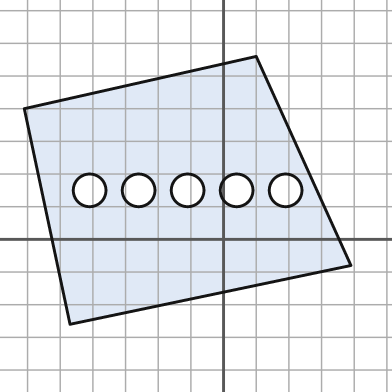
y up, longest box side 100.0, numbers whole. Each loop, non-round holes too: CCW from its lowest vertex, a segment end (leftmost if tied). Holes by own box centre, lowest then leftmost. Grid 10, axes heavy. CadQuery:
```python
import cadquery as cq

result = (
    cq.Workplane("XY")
    .moveTo(-47.0, -26.0)
    .lineTo(39.0, -8.0)
    .lineTo(10.0, 56.0)
    .lineTo(-61.0, 40.0)
    .close()
    .moveTo(-41.0, 15.0)
    .circle(5.0)
    .moveTo(-26.0, 15.0)
    .circle(5.0)
    .moveTo(-11.0, 15.0)
    .circle(5.0)
    .moveTo(4.0, 15.0)
    .circle(5.0)
    .moveTo(19.0, 15.0)
    .circle(5.0)
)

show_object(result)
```